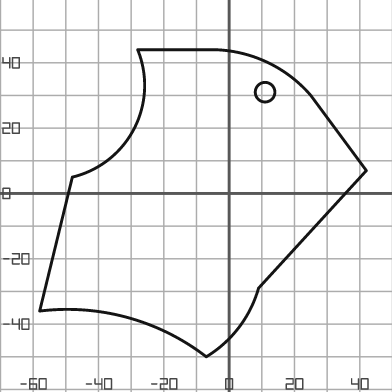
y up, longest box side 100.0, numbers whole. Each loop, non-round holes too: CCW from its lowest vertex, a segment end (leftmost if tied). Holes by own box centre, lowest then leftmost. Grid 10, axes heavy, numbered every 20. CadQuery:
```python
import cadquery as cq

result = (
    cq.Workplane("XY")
    .moveTo(-7.0, -50.0)
    .threePointArc((3.0, -41.0), (9.0, -29.0))
    .lineTo(42.0, 7.0)
    .lineTo(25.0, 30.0)
    .threePointArc((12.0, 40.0), (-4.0, 44.0))
    .lineTo(-28.0, 44.0)
    .threePointArc((-29.0, 20.0), (-48.0, 5.0))
    .lineTo(-58.0, -36.0)
    .threePointArc((-31.0, -38.0), (-7.0, -50.0))
    .close()
    .moveTo(11.0, 31.0)
    .circle(3.0)
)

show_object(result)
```